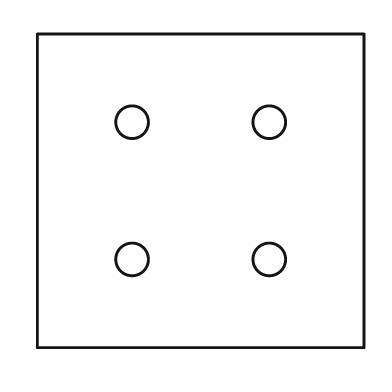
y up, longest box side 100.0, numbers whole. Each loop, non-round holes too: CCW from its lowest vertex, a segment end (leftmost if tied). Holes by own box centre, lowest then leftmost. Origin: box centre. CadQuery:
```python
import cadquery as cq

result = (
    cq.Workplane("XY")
    .moveTo(-50.0, -48.0)
    .lineTo(50.0, -48.0)
    .lineTo(50.0, 48.0)
    .lineTo(-50.0, 48.0)
    .close()
    .moveTo(-21.0, -21.0)
    .circle(5.0)
    .moveTo(21.0, -21.0)
    .circle(5.0)
    .moveTo(-21.0, 21.0)
    .circle(5.0)
    .moveTo(21.0, 21.0)
    .circle(5.0)
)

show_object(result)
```